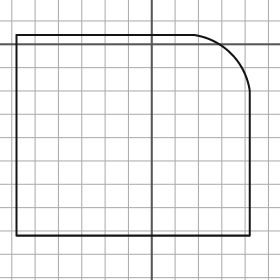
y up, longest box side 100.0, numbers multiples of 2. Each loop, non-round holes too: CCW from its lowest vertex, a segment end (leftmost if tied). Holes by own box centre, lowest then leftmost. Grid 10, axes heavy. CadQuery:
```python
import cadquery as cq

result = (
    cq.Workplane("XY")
    .moveTo(-58.0, -82.0)
    .lineTo(42.0, -82.0)
    .lineTo(42.0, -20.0)
    .threePointArc((34.0, -4.0), (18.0, 4.0))
    .lineTo(-58.0, 4.0)
    .close()
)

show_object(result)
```